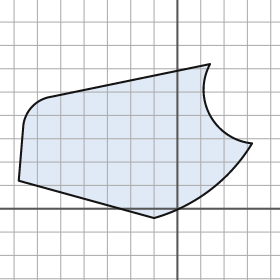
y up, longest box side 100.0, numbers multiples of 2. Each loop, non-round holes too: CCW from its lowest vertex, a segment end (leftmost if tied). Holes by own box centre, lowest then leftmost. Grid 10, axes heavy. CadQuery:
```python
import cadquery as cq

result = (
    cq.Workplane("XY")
    .moveTo(-10.0, -4.0)
    .threePointArc((14.0, 8.0), (32.0, 28.0))
    .threePointArc((14.0, 40.0), (14.0, 62.0))
    .lineTo(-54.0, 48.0)
    .threePointArc((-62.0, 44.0), (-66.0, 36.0))
    .lineTo(-68.0, 12.0)
    .close()
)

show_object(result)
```